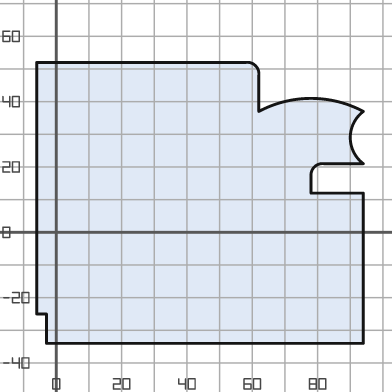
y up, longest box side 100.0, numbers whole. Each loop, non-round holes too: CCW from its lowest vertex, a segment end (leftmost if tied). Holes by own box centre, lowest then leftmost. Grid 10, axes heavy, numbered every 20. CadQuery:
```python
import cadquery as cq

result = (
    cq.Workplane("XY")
    .moveTo(-3.0, -34.0)
    .lineTo(94.0, -34.0)
    .lineTo(94.0, 12.0)
    .lineTo(78.0, 12.0)
    .lineTo(78.0, 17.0)
    .threePointArc((79.0, 20.0), (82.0, 21.0))
    .lineTo(94.0, 21.0)
    .threePointArc((90.0, 29.0), (94.0, 37.0))
    .threePointArc((78.0, 41.0), (62.0, 37.0))
    .lineTo(62.0, 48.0)
    .threePointArc((61.0, 51.0), (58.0, 52.0))
    .lineTo(-6.0, 52.0)
    .lineTo(-6.0, -25.0)
    .lineTo(-3.0, -25.0)
    .close()
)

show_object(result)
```